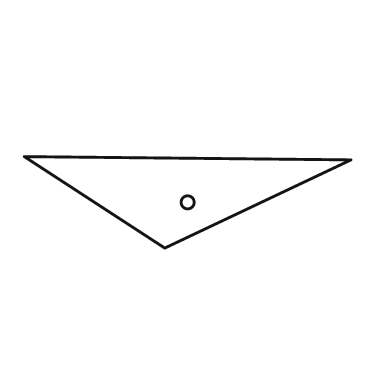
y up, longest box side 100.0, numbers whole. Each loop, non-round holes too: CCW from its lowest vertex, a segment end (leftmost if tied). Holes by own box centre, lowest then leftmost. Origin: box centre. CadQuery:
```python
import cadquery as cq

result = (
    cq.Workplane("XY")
    .moveTo(-7.0, -14.0)
    .lineTo(50.0, 13.0)
    .lineTo(-50.0, 14.0)
    .close()
    .moveTo(0.0, 0.0)
    .circle(2.0)
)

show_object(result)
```